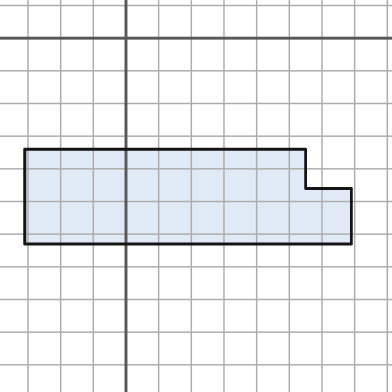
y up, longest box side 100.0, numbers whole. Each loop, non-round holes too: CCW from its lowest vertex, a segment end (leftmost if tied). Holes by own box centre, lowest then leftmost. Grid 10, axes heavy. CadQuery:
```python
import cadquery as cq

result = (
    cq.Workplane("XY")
    .moveTo(-31.0, -63.0)
    .lineTo(69.0, -63.0)
    .lineTo(69.0, -46.0)
    .lineTo(55.0, -46.0)
    .lineTo(55.0, -34.0)
    .lineTo(-31.0, -34.0)
    .close()
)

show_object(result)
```